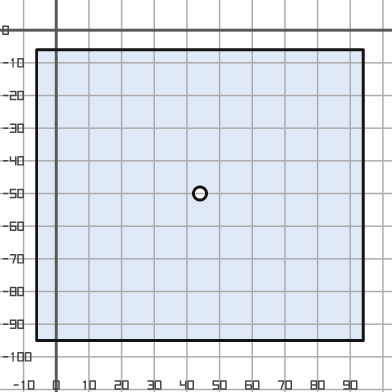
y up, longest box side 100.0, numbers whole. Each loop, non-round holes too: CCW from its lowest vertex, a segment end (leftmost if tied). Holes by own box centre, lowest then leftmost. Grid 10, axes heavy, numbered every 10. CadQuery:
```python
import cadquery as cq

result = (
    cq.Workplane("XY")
    .moveTo(-6.0, -95.0)
    .lineTo(94.0, -95.0)
    .lineTo(94.0, -6.0)
    .lineTo(-6.0, -6.0)
    .close()
    .moveTo(44.0, -50.0)
    .circle(2.0)
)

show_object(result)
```